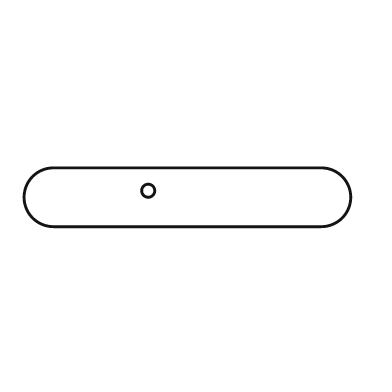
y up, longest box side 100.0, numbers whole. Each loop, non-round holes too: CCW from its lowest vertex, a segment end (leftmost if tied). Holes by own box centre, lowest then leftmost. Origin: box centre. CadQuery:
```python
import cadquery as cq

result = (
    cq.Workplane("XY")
    .moveTo(-41.0, -9.0)
    .lineTo(41.0, -9.0)
    .threePointArc((50.0, 0.0), (41.0, 9.0))
    .lineTo(-41.0, 9.0)
    .threePointArc((-50.0, 0.0), (-41.0, -9.0))
    .close()
    .moveTo(-12.0, 2.0)
    .circle(2.0)
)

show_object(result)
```